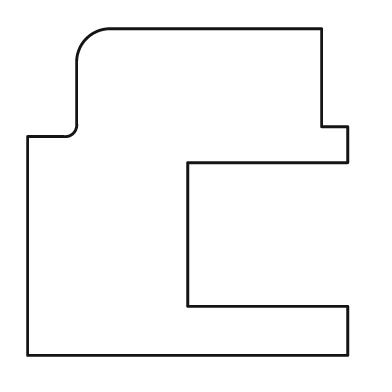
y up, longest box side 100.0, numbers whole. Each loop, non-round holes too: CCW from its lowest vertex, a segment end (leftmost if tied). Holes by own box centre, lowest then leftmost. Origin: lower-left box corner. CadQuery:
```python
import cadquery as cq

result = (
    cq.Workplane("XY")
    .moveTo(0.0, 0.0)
    .lineTo(98.0, 0.0)
    .lineTo(98.0, 15.0)
    .lineTo(49.0, 15.0)
    .lineTo(49.0, 59.0)
    .lineTo(98.0, 59.0)
    .lineTo(98.0, 70.0)
    .lineTo(90.0, 70.0)
    .lineTo(90.0, 100.0)
    .lineTo(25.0, 100.0)
    .threePointArc((18.0, 97.0), (15.0, 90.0))
    .lineTo(15.0, 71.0)
    .threePointArc((14.0, 68.0), (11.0, 67.0))
    .lineTo(0.0, 67.0)
    .close()
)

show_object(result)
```